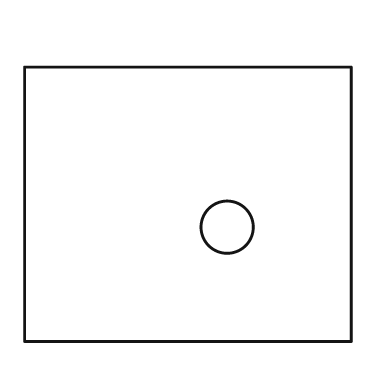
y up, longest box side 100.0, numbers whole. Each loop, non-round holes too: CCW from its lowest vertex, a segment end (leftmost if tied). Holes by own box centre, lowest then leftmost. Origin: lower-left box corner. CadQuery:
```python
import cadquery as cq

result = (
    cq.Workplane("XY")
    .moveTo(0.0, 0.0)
    .lineTo(100.0, 0.0)
    .lineTo(100.0, 84.0)
    .lineTo(0.0, 84.0)
    .close()
    .moveTo(62.0, 35.0)
    .circle(8.0)
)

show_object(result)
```